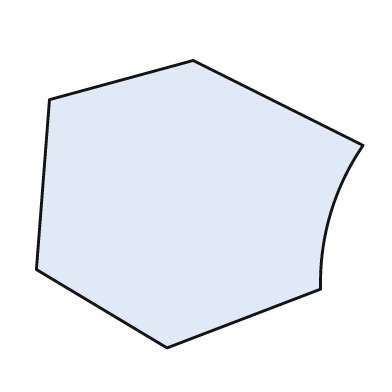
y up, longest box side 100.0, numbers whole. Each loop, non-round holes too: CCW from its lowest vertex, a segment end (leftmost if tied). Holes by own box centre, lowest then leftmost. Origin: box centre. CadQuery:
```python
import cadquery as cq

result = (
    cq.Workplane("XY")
    .moveTo(-10.0, -44.0)
    .lineTo(37.0, -26.0)
    .threePointArc((40.0, -3.0), (50.0, 18.0))
    .lineTo(-2.0, 44.0)
    .lineTo(-46.0, 32.0)
    .lineTo(-50.0, -20.0)
    .close()
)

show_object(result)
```